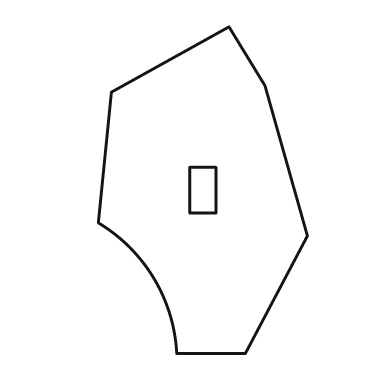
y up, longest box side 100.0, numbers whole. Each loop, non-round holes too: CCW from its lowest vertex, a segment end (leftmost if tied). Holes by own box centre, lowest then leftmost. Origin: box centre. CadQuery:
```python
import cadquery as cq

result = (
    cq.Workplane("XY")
    .moveTo(-8.0, -50.0)
    .lineTo(13.0, -50.0)
    .lineTo(32.0, -14.0)
    .lineTo(19.0, 32.0)
    .lineTo(8.0, 50.0)
    .lineTo(-28.0, 30.0)
    .lineTo(-32.0, -10.0)
    .threePointArc((-15.0, -27.0), (-8.0, -50.0))
    .close()
    .moveTo(-4.0, -7.0)
    .lineTo(4.0, -7.0)
    .lineTo(4.0, 7.0)
    .lineTo(-4.0, 7.0)
    .close()
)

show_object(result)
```